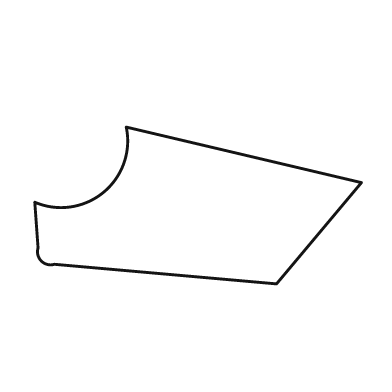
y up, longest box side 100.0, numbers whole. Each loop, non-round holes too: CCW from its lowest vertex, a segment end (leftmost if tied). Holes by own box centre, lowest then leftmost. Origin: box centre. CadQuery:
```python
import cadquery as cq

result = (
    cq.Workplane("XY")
    .moveTo(24.0, -24.0)
    .lineTo(50.0, 7.0)
    .lineTo(-22.0, 24.0)
    .threePointArc((-29.0, 4.0), (-50.0, 1.0))
    .lineTo(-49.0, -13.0)
    .threePointArc((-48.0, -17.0), (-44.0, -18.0))
    .close()
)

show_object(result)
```